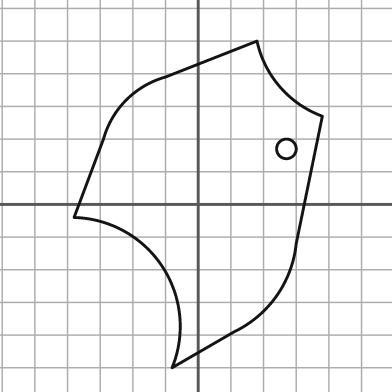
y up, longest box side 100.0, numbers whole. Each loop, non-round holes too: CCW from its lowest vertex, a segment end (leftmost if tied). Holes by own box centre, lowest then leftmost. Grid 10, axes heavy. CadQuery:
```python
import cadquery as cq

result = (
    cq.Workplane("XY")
    .moveTo(-8.0, -50.0)
    .lineTo(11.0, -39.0)
    .threePointArc((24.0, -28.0), (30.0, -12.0))
    .lineTo(38.0, 27.0)
    .threePointArc((25.0, 36.0), (18.0, 50.0))
    .lineTo(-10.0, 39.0)
    .threePointArc((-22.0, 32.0), (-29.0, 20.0))
    .lineTo(-38.0, -4.0)
    .threePointArc((-11.0, -19.0), (-8.0, -50.0))
    .close()
    .moveTo(27.0, 17.0)
    .circle(3.0)
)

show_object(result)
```